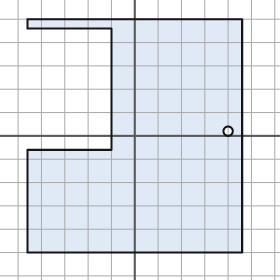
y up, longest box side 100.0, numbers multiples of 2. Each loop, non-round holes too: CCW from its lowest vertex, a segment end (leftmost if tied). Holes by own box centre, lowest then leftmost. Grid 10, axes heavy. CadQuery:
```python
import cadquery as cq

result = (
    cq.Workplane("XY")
    .moveTo(-46.0, -50.0)
    .lineTo(46.0, -50.0)
    .lineTo(46.0, 50.0)
    .lineTo(-46.0, 50.0)
    .lineTo(-46.0, 46.0)
    .lineTo(-10.0, 46.0)
    .lineTo(-10.0, -6.0)
    .lineTo(-46.0, -6.0)
    .close()
    .moveTo(40.0, 2.0)
    .circle(2.0)
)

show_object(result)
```